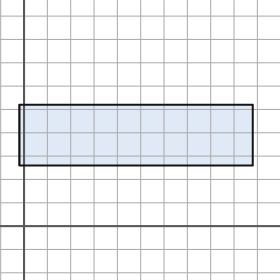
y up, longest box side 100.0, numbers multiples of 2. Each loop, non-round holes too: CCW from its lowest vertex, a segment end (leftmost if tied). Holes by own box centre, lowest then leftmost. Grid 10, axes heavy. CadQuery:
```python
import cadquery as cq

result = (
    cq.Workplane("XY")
    .moveTo(-2.0, 26.0)
    .lineTo(98.0, 26.0)
    .lineTo(98.0, 52.0)
    .lineTo(-2.0, 52.0)
    .close()
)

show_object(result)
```